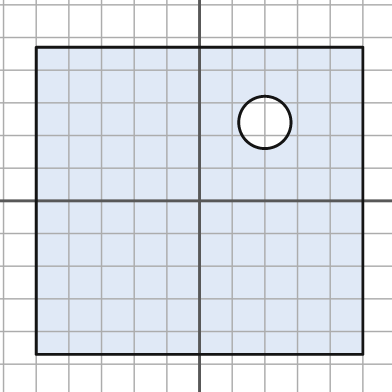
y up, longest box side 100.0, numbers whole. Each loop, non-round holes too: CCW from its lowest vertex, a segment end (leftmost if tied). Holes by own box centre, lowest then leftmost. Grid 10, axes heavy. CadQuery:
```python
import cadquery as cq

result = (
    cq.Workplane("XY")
    .moveTo(-50.0, -47.0)
    .lineTo(50.0, -47.0)
    .lineTo(50.0, 47.0)
    .lineTo(-50.0, 47.0)
    .close()
    .moveTo(20.0, 24.0)
    .circle(8.0)
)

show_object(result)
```